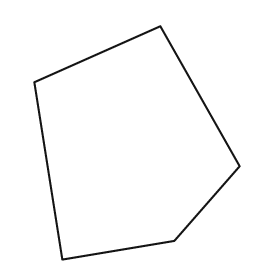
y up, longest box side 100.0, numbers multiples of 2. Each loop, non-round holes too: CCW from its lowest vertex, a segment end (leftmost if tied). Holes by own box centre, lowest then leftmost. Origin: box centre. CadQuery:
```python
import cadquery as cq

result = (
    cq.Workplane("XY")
    .moveTo(-32.0, -50.0)
    .lineTo(16.0, -42.0)
    .lineTo(44.0, -10.0)
    .lineTo(10.0, 50.0)
    .lineTo(-44.0, 26.0)
    .close()
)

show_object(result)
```